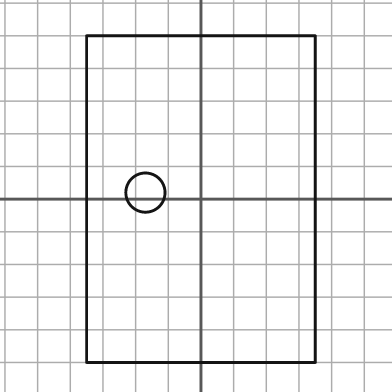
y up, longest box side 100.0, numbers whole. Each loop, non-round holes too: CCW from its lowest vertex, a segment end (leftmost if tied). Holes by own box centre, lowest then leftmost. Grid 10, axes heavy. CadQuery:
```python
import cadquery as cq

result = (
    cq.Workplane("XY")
    .moveTo(-35.0, -50.0)
    .lineTo(35.0, -50.0)
    .lineTo(35.0, 50.0)
    .lineTo(-35.0, 50.0)
    .close()
    .moveTo(-17.0, 2.0)
    .circle(6.0)
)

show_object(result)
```